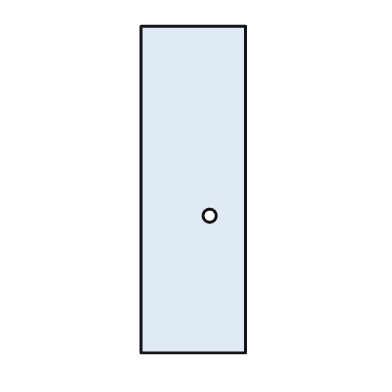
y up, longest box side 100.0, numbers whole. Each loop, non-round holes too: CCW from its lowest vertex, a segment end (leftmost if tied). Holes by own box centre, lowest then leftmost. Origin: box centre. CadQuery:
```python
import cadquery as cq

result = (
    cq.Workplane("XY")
    .moveTo(-16.0, -50.0)
    .lineTo(16.0, -50.0)
    .lineTo(16.0, 50.0)
    .lineTo(-16.0, 50.0)
    .close()
    .moveTo(5.0, -8.0)
    .circle(2.0)
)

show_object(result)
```